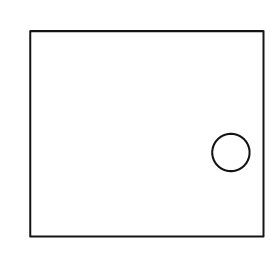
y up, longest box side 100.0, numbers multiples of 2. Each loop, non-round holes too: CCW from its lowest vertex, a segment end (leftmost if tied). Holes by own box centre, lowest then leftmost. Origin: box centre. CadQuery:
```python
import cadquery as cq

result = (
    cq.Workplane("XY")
    .moveTo(-50.0, -44.0)
    .lineTo(50.0, -44.0)
    .lineTo(50.0, 44.0)
    .lineTo(-50.0, 44.0)
    .close()
    .moveTo(36.0, -8.0)
    .circle(8.0)
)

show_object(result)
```